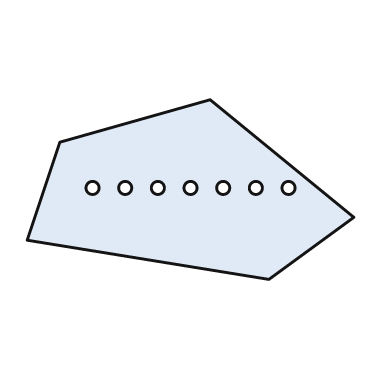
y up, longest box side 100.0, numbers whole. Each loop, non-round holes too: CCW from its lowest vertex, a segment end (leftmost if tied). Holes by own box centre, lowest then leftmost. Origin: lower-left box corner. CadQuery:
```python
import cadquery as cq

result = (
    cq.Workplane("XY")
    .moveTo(74.0, 0.0)
    .lineTo(100.0, 19.0)
    .lineTo(56.0, 55.0)
    .lineTo(10.0, 42.0)
    .lineTo(0.0, 12.0)
    .close()
    .moveTo(20.0, 28.0)
    .circle(2.0)
    .moveTo(30.0, 28.0)
    .circle(2.0)
    .moveTo(40.0, 28.0)
    .circle(2.0)
    .moveTo(50.0, 28.0)
    .circle(2.0)
    .moveTo(60.0, 28.0)
    .circle(2.0)
    .moveTo(70.0, 28.0)
    .circle(2.0)
    .moveTo(80.0, 28.0)
    .circle(2.0)
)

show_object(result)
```